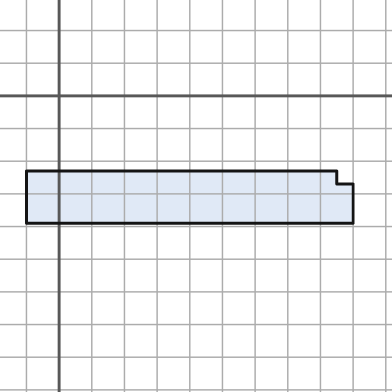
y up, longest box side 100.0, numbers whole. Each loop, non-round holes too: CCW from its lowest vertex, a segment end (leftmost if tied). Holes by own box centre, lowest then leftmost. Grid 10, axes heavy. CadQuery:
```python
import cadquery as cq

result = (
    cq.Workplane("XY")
    .moveTo(-10.0, -39.0)
    .lineTo(90.0, -39.0)
    .lineTo(90.0, -27.0)
    .lineTo(85.0, -27.0)
    .lineTo(85.0, -23.0)
    .lineTo(-10.0, -23.0)
    .close()
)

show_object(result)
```